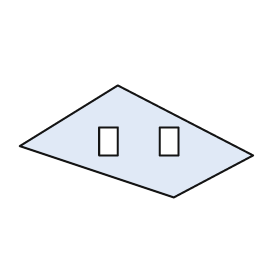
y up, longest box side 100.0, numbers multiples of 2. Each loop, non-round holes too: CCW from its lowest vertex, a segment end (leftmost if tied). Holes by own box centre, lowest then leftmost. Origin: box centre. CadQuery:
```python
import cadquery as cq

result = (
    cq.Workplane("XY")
    .moveTo(16.0, -24.0)
    .lineTo(50.0, -6.0)
    .lineTo(-8.0, 24.0)
    .lineTo(-50.0, -2.0)
    .close()
    .moveTo(-16.0, -6.0)
    .lineTo(-8.0, -6.0)
    .lineTo(-8.0, 6.0)
    .lineTo(-16.0, 6.0)
    .close()
    .moveTo(10.0, -6.0)
    .lineTo(18.0, -6.0)
    .lineTo(18.0, 6.0)
    .lineTo(10.0, 6.0)
    .close()
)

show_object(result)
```